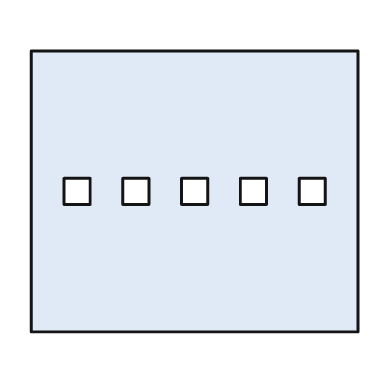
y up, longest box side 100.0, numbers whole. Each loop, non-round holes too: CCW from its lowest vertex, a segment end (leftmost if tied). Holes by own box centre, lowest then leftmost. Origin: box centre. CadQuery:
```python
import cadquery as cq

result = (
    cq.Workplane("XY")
    .moveTo(-50.0, -43.0)
    .lineTo(50.0, -43.0)
    .lineTo(50.0, 43.0)
    .lineTo(-50.0, 43.0)
    .close()
    .moveTo(-40.0, -4.0)
    .lineTo(-32.0, -4.0)
    .lineTo(-32.0, 4.0)
    .lineTo(-40.0, 4.0)
    .close()
    .moveTo(-22.0, -4.0)
    .lineTo(-14.0, -4.0)
    .lineTo(-14.0, 4.0)
    .lineTo(-22.0, 4.0)
    .close()
    .moveTo(-4.0, -4.0)
    .lineTo(4.0, -4.0)
    .lineTo(4.0, 4.0)
    .lineTo(-4.0, 4.0)
    .close()
    .moveTo(14.0, -4.0)
    .lineTo(22.0, -4.0)
    .lineTo(22.0, 4.0)
    .lineTo(14.0, 4.0)
    .close()
    .moveTo(32.0, -4.0)
    .lineTo(40.0, -4.0)
    .lineTo(40.0, 4.0)
    .lineTo(32.0, 4.0)
    .close()
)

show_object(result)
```